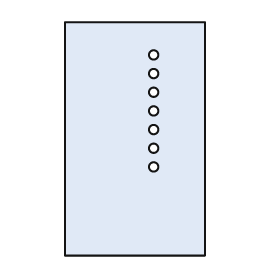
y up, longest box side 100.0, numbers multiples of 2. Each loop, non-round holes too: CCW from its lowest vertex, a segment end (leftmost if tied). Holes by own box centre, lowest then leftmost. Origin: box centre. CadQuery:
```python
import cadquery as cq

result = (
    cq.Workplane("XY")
    .moveTo(-30.0, -50.0)
    .lineTo(30.0, -50.0)
    .lineTo(30.0, 50.0)
    .lineTo(-30.0, 50.0)
    .close()
    .moveTo(8.0, -12.0)
    .circle(2.0)
    .moveTo(8.0, -4.0)
    .circle(2.0)
    .moveTo(8.0, 4.0)
    .circle(2.0)
    .moveTo(8.0, 12.0)
    .circle(2.0)
    .moveTo(8.0, 20.0)
    .circle(2.0)
    .moveTo(8.0, 28.0)
    .circle(2.0)
    .moveTo(8.0, 36.0)
    .circle(2.0)
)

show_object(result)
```